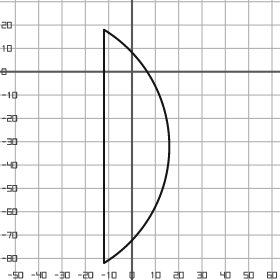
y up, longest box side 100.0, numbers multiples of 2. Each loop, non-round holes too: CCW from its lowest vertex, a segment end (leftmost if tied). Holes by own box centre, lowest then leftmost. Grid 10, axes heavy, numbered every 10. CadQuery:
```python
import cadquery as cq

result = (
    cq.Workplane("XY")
    .moveTo(-12.0, -82.0)
    .threePointArc((16.0, -32.0), (-12.0, 18.0))
    .close()
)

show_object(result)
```